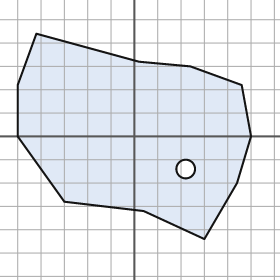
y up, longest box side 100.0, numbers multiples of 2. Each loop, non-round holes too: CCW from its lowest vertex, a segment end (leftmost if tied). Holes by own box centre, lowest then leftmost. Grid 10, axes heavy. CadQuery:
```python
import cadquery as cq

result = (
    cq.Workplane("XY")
    .moveTo(30.0, -44.0)
    .lineTo(44.0, -20.0)
    .lineTo(50.0, 0.0)
    .lineTo(46.0, 22.0)
    .lineTo(24.0, 30.0)
    .lineTo(2.0, 32.0)
    .lineTo(-42.0, 44.0)
    .lineTo(-50.0, 22.0)
    .lineTo(-50.0, 0.0)
    .lineTo(-30.0, -28.0)
    .lineTo(4.0, -32.0)
    .close()
    .moveTo(22.0, -14.0)
    .circle(4.0)
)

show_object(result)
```